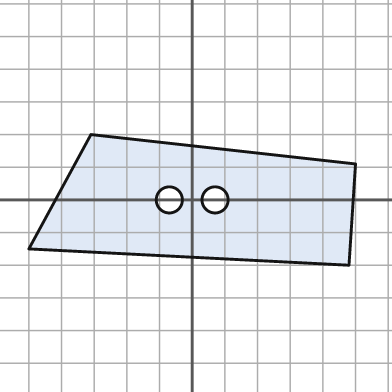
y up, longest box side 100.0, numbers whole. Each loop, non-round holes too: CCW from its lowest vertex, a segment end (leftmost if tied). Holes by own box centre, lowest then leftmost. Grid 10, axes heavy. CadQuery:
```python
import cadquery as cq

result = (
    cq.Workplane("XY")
    .moveTo(48.0, -20.0)
    .lineTo(50.0, 11.0)
    .lineTo(-31.0, 20.0)
    .lineTo(-50.0, -15.0)
    .close()
    .moveTo(-7.0, 0.0)
    .circle(4.0)
    .moveTo(7.0, 0.0)
    .circle(4.0)
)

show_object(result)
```